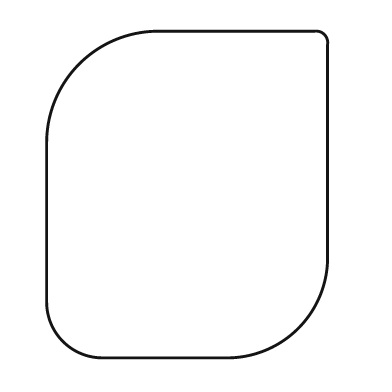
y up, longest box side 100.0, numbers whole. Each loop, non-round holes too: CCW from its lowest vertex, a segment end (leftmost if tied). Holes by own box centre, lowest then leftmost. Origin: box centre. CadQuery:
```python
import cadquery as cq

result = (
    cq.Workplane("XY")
    .moveTo(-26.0, -50.0)
    .lineTo(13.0, -50.0)
    .threePointArc((34.0, -41.0), (43.0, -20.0))
    .lineTo(43.0, 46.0)
    .threePointArc((42.0, 49.0), (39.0, 50.0))
    .lineTo(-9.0, 50.0)
    .threePointArc((-33.0, 40.0), (-43.0, 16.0))
    .lineTo(-43.0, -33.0)
    .threePointArc((-38.0, -45.0), (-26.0, -50.0))
    .close()
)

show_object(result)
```